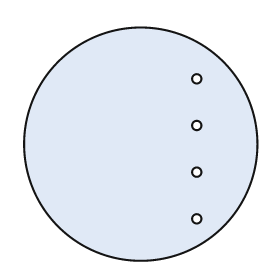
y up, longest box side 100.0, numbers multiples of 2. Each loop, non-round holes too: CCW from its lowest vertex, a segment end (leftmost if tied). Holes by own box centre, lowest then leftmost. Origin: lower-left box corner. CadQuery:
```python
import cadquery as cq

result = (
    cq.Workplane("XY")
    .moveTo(50.0, 50.0)
    .circle(50.0)
    .moveTo(74.0, 18.0)
    .circle(2.0)
    .moveTo(74.0, 38.0)
    .circle(2.0)
    .moveTo(74.0, 58.0)
    .circle(2.0)
    .moveTo(74.0, 78.0)
    .circle(2.0)
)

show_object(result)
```